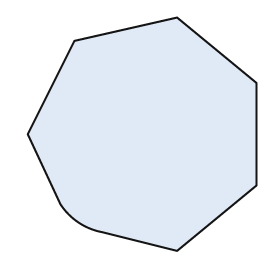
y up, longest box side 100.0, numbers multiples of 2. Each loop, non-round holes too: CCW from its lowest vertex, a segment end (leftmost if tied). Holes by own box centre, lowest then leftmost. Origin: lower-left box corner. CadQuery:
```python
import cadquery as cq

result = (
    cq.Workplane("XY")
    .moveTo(64.0, 0.0)
    .lineTo(98.0, 28.0)
    .lineTo(98.0, 72.0)
    .lineTo(64.0, 100.0)
    .lineTo(20.0, 90.0)
    .lineTo(0.0, 50.0)
    .lineTo(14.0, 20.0)
    .threePointArc((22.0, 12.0), (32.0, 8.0))
    .close()
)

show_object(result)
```